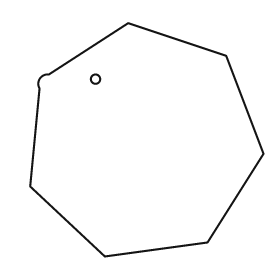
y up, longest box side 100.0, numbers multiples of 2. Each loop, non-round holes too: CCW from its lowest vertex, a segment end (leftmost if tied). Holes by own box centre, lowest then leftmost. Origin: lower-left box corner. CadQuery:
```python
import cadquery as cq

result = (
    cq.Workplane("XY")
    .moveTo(32.0, 0.0)
    .lineTo(76.0, 6.0)
    .lineTo(100.0, 44.0)
    .lineTo(84.0, 86.0)
    .lineTo(42.0, 100.0)
    .lineTo(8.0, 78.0)
    .threePointArc((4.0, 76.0), (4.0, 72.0))
    .lineTo(0.0, 30.0)
    .close()
    .moveTo(28.0, 76.0)
    .circle(2.0)
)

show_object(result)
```